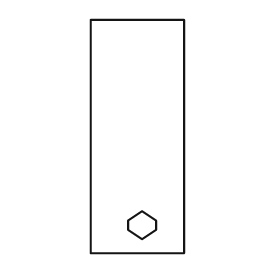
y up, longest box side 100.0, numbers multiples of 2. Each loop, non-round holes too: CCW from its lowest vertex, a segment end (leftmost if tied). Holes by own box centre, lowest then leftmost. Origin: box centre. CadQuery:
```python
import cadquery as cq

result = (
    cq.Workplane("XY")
    .moveTo(-20.0, -50.0)
    .lineTo(20.0, -50.0)
    .lineTo(20.0, 50.0)
    .lineTo(-20.0, 50.0)
    .close()
    .moveTo(2.0, -44.0)
    .lineTo(8.0, -40.0)
    .lineTo(8.0, -36.0)
    .lineTo(2.0, -32.0)
    .lineTo(-4.0, -36.0)
    .lineTo(-4.0, -40.0)
    .close()
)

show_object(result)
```